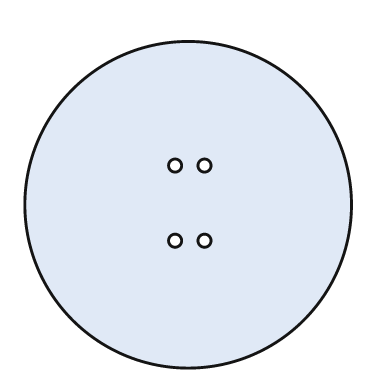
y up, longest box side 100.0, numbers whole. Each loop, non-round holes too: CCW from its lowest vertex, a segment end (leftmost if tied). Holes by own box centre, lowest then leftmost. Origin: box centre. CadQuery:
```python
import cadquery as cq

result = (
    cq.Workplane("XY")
    .moveTo(0.0, 0.0)
    .circle(50.0)
    .moveTo(-4.0, -11.0)
    .circle(2.0)
    .moveTo(5.0, -11.0)
    .circle(2.0)
    .moveTo(-4.0, 12.0)
    .circle(2.0)
    .moveTo(5.0, 12.0)
    .circle(2.0)
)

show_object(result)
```